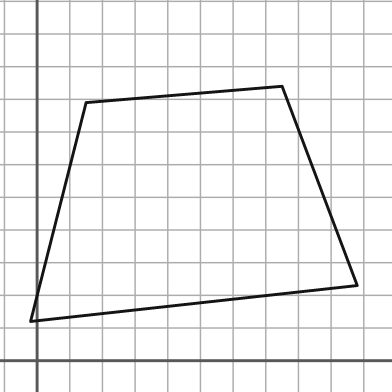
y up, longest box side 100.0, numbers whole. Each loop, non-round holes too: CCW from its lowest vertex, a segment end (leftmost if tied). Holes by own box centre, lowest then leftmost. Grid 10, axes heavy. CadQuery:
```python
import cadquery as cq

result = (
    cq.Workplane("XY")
    .moveTo(-2.0, 12.0)
    .lineTo(98.0, 23.0)
    .lineTo(75.0, 84.0)
    .lineTo(15.0, 79.0)
    .close()
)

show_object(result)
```